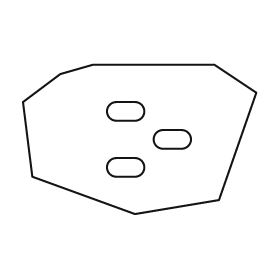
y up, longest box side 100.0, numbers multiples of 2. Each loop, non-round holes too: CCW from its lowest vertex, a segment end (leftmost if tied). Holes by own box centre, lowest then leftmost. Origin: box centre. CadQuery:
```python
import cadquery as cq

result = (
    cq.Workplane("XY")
    .moveTo(-2.0, -32.0)
    .lineTo(34.0, -26.0)
    .lineTo(50.0, 20.0)
    .lineTo(32.0, 32.0)
    .lineTo(-20.0, 32.0)
    .lineTo(-34.0, 28.0)
    .lineTo(-50.0, 16.0)
    .lineTo(-46.0, -16.0)
    .close()
    .moveTo(-10.0, -16.0)
    .lineTo(-2.0, -16.0)
    .threePointArc((2.0, -12.0), (-2.0, -8.0))
    .lineTo(-10.0, -8.0)
    .threePointArc((-14.0, -12.0), (-10.0, -16.0))
    .close()
    .moveTo(10.0, -4.0)
    .lineTo(18.0, -4.0)
    .threePointArc((22.0, 0.0), (18.0, 4.0))
    .lineTo(10.0, 4.0)
    .threePointArc((6.0, 0.0), (10.0, -4.0))
    .close()
    .moveTo(-10.0, 8.0)
    .lineTo(-2.0, 8.0)
    .threePointArc((2.0, 12.0), (-2.0, 16.0))
    .lineTo(-10.0, 16.0)
    .threePointArc((-14.0, 12.0), (-10.0, 8.0))
    .close()
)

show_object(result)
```